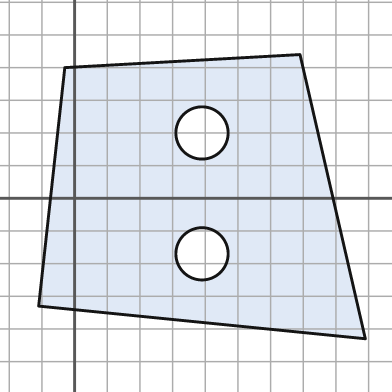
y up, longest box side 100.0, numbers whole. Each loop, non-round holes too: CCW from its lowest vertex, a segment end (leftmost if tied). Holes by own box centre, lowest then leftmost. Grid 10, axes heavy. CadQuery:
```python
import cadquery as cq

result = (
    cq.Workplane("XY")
    .moveTo(89.0, -43.0)
    .lineTo(69.0, 44.0)
    .lineTo(-3.0, 40.0)
    .lineTo(-11.0, -33.0)
    .close()
    .moveTo(39.0, -17.0)
    .circle(8.0)
    .moveTo(39.0, 20.0)
    .circle(8.0)
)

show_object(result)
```